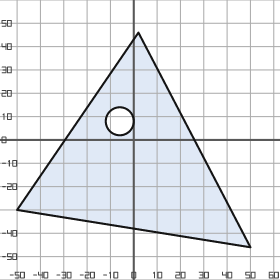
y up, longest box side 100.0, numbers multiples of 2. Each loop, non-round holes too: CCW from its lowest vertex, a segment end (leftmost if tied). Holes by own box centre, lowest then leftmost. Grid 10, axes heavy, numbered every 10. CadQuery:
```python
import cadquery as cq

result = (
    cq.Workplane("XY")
    .moveTo(50.0, -46.0)
    .lineTo(2.0, 46.0)
    .lineTo(-50.0, -30.0)
    .close()
    .moveTo(-6.0, 8.0)
    .circle(6.0)
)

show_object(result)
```